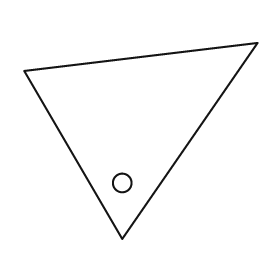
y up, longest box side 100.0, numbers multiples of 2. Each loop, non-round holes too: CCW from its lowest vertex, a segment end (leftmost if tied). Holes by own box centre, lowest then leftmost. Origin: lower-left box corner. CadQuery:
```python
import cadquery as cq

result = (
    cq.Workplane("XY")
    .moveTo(42.0, 0.0)
    .lineTo(100.0, 84.0)
    .lineTo(0.0, 72.0)
    .close()
    .moveTo(42.0, 24.0)
    .circle(4.0)
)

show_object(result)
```